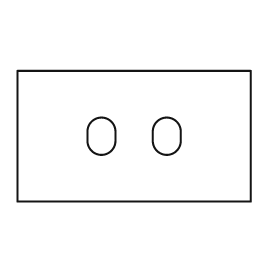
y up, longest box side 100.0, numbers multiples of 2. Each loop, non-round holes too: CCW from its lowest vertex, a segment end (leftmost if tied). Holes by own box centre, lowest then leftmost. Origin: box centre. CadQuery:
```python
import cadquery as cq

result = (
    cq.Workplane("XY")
    .moveTo(-50.0, -28.0)
    .lineTo(50.0, -28.0)
    .lineTo(50.0, 28.0)
    .lineTo(-50.0, 28.0)
    .close()
    .moveTo(-20.0, -2.0)
    .threePointArc((-14.0, -8.0), (-8.0, -2.0))
    .lineTo(-8.0, 2.0)
    .threePointArc((-14.0, 8.0), (-20.0, 2.0))
    .close()
    .moveTo(8.0, -2.0)
    .threePointArc((14.0, -8.0), (20.0, -2.0))
    .lineTo(20.0, 2.0)
    .threePointArc((14.0, 8.0), (8.0, 2.0))
    .close()
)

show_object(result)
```